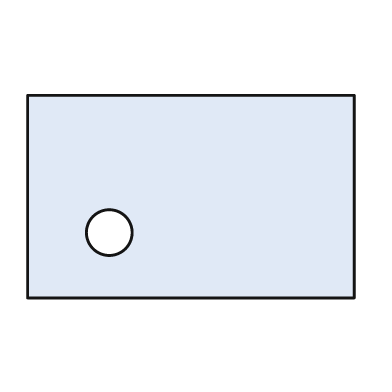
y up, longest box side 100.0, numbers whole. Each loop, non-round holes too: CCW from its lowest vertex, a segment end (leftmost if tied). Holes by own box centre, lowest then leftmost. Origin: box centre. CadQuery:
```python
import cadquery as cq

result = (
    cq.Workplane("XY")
    .moveTo(-50.0, -31.0)
    .lineTo(50.0, -31.0)
    .lineTo(50.0, 31.0)
    .lineTo(-50.0, 31.0)
    .close()
    .moveTo(-25.0, -11.0)
    .circle(7.0)
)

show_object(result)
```